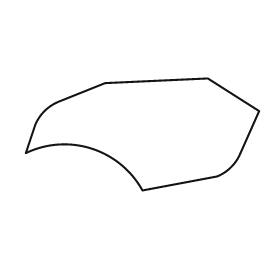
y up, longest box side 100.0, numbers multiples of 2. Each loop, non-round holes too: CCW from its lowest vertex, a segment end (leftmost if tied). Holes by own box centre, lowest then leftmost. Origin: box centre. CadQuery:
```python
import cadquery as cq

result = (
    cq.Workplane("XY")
    .moveTo(0.0, -24.0)
    .lineTo(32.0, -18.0)
    .threePointArc((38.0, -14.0), (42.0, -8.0))
    .lineTo(50.0, 10.0)
    .lineTo(28.0, 24.0)
    .lineTo(-16.0, 22.0)
    .lineTo(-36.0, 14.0)
    .threePointArc((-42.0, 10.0), (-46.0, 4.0))
    .lineTo(-50.0, -8.0)
    .threePointArc((-22.0, -6.0), (0.0, -24.0))
    .close()
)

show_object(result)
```